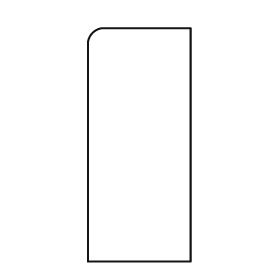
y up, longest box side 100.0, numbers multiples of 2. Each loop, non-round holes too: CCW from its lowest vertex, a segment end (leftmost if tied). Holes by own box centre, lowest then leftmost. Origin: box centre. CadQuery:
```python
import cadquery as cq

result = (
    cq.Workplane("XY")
    .moveTo(-22.0, -50.0)
    .lineTo(22.0, -50.0)
    .lineTo(22.0, 50.0)
    .lineTo(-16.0, 50.0)
    .threePointArc((-20.0, 48.0), (-22.0, 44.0))
    .close()
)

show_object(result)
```